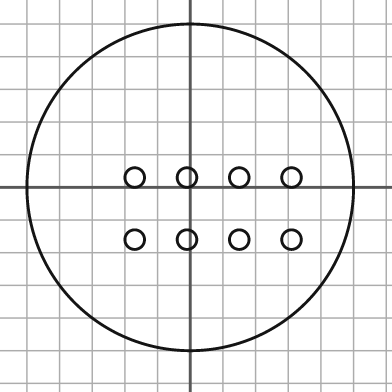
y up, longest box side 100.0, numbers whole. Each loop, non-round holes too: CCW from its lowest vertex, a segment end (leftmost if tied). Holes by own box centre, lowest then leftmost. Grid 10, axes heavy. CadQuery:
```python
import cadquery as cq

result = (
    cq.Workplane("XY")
    .moveTo(0.0, 0.0)
    .circle(50.0)
    .moveTo(-17.0, -16.0)
    .circle(3.0)
    .moveTo(-1.0, -16.0)
    .circle(3.0)
    .moveTo(15.0, -16.0)
    .circle(3.0)
    .moveTo(31.0, -16.0)
    .circle(3.0)
    .moveTo(-17.0, 3.0)
    .circle(3.0)
    .moveTo(-1.0, 3.0)
    .circle(3.0)
    .moveTo(15.0, 3.0)
    .circle(3.0)
    .moveTo(31.0, 3.0)
    .circle(3.0)
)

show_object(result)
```